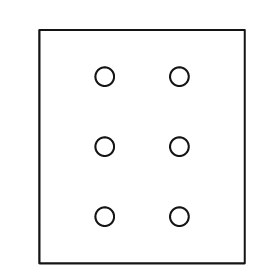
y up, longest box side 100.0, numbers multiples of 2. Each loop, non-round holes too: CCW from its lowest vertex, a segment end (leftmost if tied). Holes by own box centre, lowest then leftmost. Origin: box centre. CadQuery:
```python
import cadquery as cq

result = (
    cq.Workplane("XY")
    .moveTo(-44.0, -50.0)
    .lineTo(44.0, -50.0)
    .lineTo(44.0, 50.0)
    .lineTo(-44.0, 50.0)
    .close()
    .moveTo(-16.0, -30.0)
    .circle(4.0)
    .moveTo(16.0, -30.0)
    .circle(4.0)
    .moveTo(-16.0, 0.0)
    .circle(4.0)
    .moveTo(16.0, 0.0)
    .circle(4.0)
    .moveTo(-16.0, 30.0)
    .circle(4.0)
    .moveTo(16.0, 30.0)
    .circle(4.0)
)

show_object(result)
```